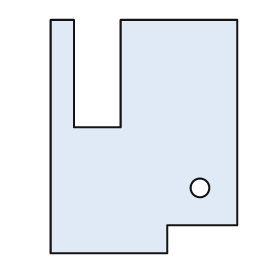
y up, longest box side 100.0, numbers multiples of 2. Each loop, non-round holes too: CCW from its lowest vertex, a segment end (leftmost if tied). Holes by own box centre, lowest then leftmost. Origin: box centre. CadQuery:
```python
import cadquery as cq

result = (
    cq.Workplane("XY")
    .moveTo(-40.0, -50.0)
    .lineTo(10.0, -50.0)
    .lineTo(10.0, -38.0)
    .lineTo(40.0, -38.0)
    .lineTo(40.0, 50.0)
    .lineTo(-10.0, 50.0)
    .lineTo(-10.0, 4.0)
    .lineTo(-30.0, 4.0)
    .lineTo(-30.0, 50.0)
    .lineTo(-40.0, 50.0)
    .close()
    .moveTo(24.0, -22.0)
    .circle(4.0)
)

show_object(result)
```